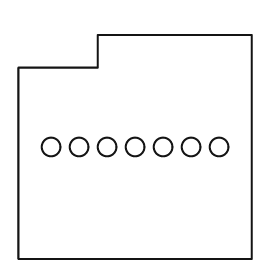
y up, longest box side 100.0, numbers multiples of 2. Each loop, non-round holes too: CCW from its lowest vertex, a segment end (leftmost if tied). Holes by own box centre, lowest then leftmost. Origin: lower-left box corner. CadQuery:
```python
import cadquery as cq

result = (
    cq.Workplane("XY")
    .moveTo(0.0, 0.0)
    .lineTo(100.0, 0.0)
    .lineTo(100.0, 96.0)
    .lineTo(34.0, 96.0)
    .lineTo(34.0, 82.0)
    .lineTo(0.0, 82.0)
    .close()
    .moveTo(14.0, 48.0)
    .circle(4.0)
    .moveTo(26.0, 48.0)
    .circle(4.0)
    .moveTo(38.0, 48.0)
    .circle(4.0)
    .moveTo(50.0, 48.0)
    .circle(4.0)
    .moveTo(62.0, 48.0)
    .circle(4.0)
    .moveTo(74.0, 48.0)
    .circle(4.0)
    .moveTo(86.0, 48.0)
    .circle(4.0)
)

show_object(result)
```